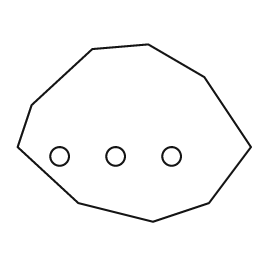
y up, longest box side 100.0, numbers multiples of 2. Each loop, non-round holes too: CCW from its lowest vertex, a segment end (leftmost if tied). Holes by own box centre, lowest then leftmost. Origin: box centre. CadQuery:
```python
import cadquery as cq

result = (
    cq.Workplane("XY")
    .moveTo(8.0, -38.0)
    .lineTo(32.0, -30.0)
    .lineTo(50.0, -6.0)
    .lineTo(30.0, 24.0)
    .lineTo(6.0, 38.0)
    .lineTo(-18.0, 36.0)
    .lineTo(-44.0, 12.0)
    .lineTo(-50.0, -6.0)
    .lineTo(-24.0, -30.0)
    .close()
    .moveTo(-32.0, -10.0)
    .circle(4.0)
    .moveTo(-8.0, -10.0)
    .circle(4.0)
    .moveTo(16.0, -10.0)
    .circle(4.0)
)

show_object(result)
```